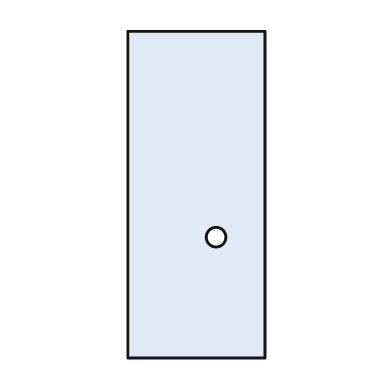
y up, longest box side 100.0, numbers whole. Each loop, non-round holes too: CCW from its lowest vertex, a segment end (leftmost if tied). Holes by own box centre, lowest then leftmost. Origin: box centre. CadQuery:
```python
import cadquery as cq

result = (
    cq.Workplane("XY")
    .moveTo(-21.0, -50.0)
    .lineTo(21.0, -50.0)
    .lineTo(21.0, 50.0)
    .lineTo(-21.0, 50.0)
    .close()
    .moveTo(6.0, -13.0)
    .circle(3.0)
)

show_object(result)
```